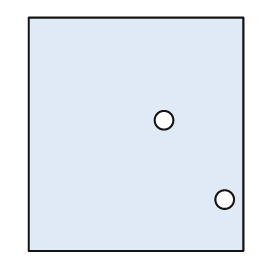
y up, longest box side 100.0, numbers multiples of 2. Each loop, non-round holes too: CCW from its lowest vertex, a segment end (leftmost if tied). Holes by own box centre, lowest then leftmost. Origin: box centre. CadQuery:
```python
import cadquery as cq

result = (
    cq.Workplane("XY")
    .moveTo(-46.0, -50.0)
    .lineTo(46.0, -50.0)
    .lineTo(46.0, 50.0)
    .lineTo(-46.0, 50.0)
    .close()
    .moveTo(38.0, -28.0)
    .circle(4.0)
    .moveTo(12.0, 6.0)
    .circle(4.0)
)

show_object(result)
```